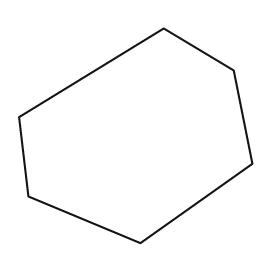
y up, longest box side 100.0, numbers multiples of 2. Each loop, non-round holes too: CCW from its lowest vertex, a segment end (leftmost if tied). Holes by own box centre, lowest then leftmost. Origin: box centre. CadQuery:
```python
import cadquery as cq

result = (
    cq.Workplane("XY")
    .moveTo(2.0, -46.0)
    .lineTo(50.0, -12.0)
    .lineTo(42.0, 28.0)
    .lineTo(12.0, 46.0)
    .lineTo(-50.0, 8.0)
    .lineTo(-46.0, -26.0)
    .close()
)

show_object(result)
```